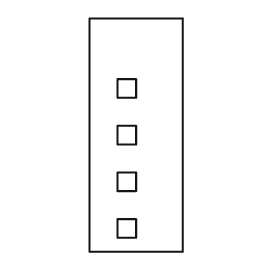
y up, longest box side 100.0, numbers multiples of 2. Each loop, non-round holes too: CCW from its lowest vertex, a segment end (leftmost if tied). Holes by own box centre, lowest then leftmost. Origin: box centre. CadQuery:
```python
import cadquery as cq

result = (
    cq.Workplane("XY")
    .moveTo(-20.0, -50.0)
    .lineTo(20.0, -50.0)
    .lineTo(20.0, 50.0)
    .lineTo(-20.0, 50.0)
    .close()
    .moveTo(-8.0, -44.0)
    .lineTo(0.0, -44.0)
    .lineTo(0.0, -36.0)
    .lineTo(-8.0, -36.0)
    .close()
    .moveTo(-8.0, -24.0)
    .lineTo(0.0, -24.0)
    .lineTo(0.0, -16.0)
    .lineTo(-8.0, -16.0)
    .close()
    .moveTo(-8.0, -4.0)
    .lineTo(0.0, -4.0)
    .lineTo(0.0, 4.0)
    .lineTo(-8.0, 4.0)
    .close()
    .moveTo(-8.0, 16.0)
    .lineTo(0.0, 16.0)
    .lineTo(0.0, 24.0)
    .lineTo(-8.0, 24.0)
    .close()
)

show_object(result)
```